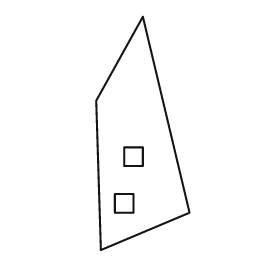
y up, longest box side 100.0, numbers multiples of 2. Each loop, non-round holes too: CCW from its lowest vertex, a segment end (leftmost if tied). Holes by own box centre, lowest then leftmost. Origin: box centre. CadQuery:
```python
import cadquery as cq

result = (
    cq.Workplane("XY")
    .moveTo(-18.0, -50.0)
    .lineTo(20.0, -34.0)
    .lineTo(0.0, 50.0)
    .lineTo(-20.0, 14.0)
    .close()
    .moveTo(-12.0, -34.0)
    .lineTo(-4.0, -34.0)
    .lineTo(-4.0, -26.0)
    .lineTo(-12.0, -26.0)
    .close()
    .moveTo(-8.0, -14.0)
    .lineTo(0.0, -14.0)
    .lineTo(0.0, -6.0)
    .lineTo(-8.0, -6.0)
    .close()
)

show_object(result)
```